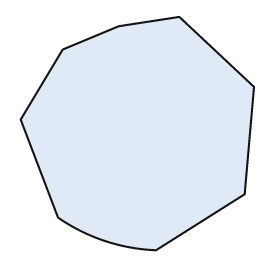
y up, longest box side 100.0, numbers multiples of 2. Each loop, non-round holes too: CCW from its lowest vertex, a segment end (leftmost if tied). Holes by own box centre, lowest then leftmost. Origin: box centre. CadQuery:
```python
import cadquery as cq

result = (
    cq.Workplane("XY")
    .moveTo(8.0, -50.0)
    .lineTo(46.0, -26.0)
    .lineTo(50.0, 20.0)
    .lineTo(18.0, 50.0)
    .lineTo(-8.0, 46.0)
    .lineTo(-32.0, 36.0)
    .lineTo(-50.0, 6.0)
    .lineTo(-34.0, -36.0)
    .threePointArc((-14.0, -46.0), (8.0, -50.0))
    .close()
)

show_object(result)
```